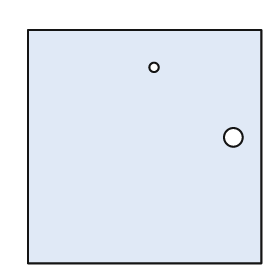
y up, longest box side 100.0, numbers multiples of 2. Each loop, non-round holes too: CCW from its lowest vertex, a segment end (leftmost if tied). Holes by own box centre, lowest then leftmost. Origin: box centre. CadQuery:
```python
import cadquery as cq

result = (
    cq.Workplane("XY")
    .moveTo(-50.0, -50.0)
    .lineTo(50.0, -50.0)
    .lineTo(50.0, 50.0)
    .lineTo(-50.0, 50.0)
    .close()
    .moveTo(38.0, 4.0)
    .circle(4.0)
    .moveTo(4.0, 34.0)
    .circle(2.0)
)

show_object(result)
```